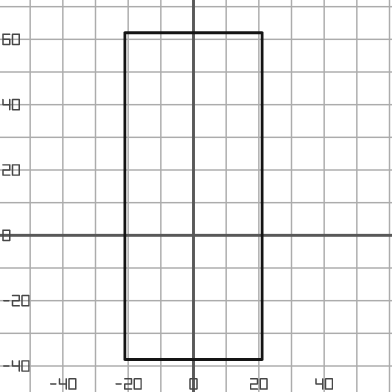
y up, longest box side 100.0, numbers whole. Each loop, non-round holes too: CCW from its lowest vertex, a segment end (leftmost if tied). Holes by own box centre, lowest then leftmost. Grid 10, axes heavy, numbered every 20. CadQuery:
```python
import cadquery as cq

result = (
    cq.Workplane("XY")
    .moveTo(-21.0, -38.0)
    .lineTo(21.0, -38.0)
    .lineTo(21.0, 62.0)
    .lineTo(-21.0, 62.0)
    .close()
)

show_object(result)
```